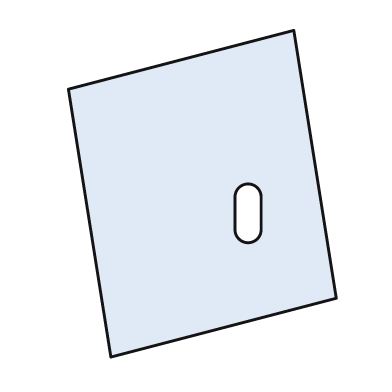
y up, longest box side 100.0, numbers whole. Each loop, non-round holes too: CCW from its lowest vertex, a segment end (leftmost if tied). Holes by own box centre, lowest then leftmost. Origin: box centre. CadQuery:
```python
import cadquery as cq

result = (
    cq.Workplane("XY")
    .moveTo(-28.0, -50.0)
    .lineTo(41.0, -32.0)
    .lineTo(28.0, 50.0)
    .lineTo(-41.0, 32.0)
    .close()
    .moveTo(10.0, -11.0)
    .threePointArc((14.0, -15.0), (18.0, -11.0))
    .lineTo(18.0, -1.0)
    .threePointArc((14.0, 3.0), (10.0, -1.0))
    .close()
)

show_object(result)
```